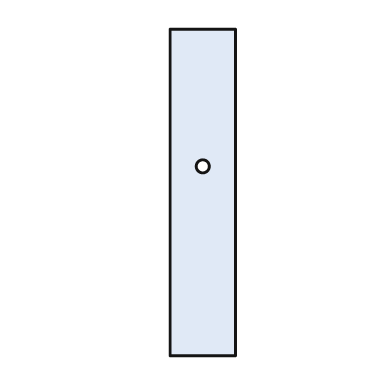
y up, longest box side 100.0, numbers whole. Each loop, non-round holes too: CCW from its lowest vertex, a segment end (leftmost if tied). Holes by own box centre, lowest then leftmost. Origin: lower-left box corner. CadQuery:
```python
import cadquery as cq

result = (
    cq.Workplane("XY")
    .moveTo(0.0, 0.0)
    .lineTo(20.0, 0.0)
    .lineTo(20.0, 100.0)
    .lineTo(0.0, 100.0)
    .close()
    .moveTo(10.0, 58.0)
    .circle(2.0)
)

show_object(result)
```